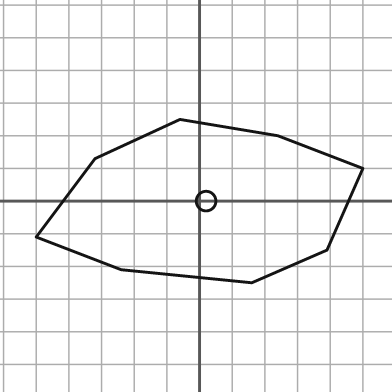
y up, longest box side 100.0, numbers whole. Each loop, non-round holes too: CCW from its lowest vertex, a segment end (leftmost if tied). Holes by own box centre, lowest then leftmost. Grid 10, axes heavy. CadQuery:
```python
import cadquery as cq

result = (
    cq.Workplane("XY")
    .moveTo(16.0, -25.0)
    .lineTo(39.0, -15.0)
    .lineTo(50.0, 10.0)
    .lineTo(24.0, 20.0)
    .lineTo(-6.0, 25.0)
    .lineTo(-32.0, 13.0)
    .lineTo(-50.0, -11.0)
    .lineTo(-24.0, -21.0)
    .close()
    .moveTo(2.0, 0.0)
    .circle(3.0)
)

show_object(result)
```